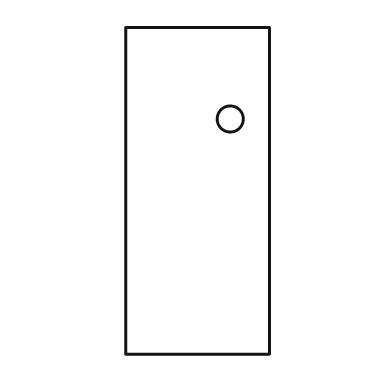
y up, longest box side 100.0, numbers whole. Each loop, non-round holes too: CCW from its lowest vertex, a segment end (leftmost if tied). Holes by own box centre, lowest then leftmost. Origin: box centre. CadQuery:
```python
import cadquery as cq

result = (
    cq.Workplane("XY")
    .moveTo(-22.0, -50.0)
    .lineTo(22.0, -50.0)
    .lineTo(22.0, 50.0)
    .lineTo(-22.0, 50.0)
    .close()
    .moveTo(10.0, 22.0)
    .circle(4.0)
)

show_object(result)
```